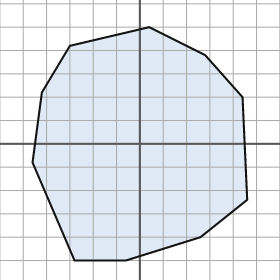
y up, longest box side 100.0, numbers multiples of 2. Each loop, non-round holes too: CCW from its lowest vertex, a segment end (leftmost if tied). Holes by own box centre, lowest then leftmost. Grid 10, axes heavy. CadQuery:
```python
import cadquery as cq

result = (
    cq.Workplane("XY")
    .moveTo(-28.0, -50.0)
    .lineTo(-6.0, -50.0)
    .lineTo(26.0, -40.0)
    .lineTo(46.0, -24.0)
    .lineTo(44.0, 20.0)
    .lineTo(28.0, 38.0)
    .lineTo(4.0, 50.0)
    .lineTo(-30.0, 42.0)
    .lineTo(-42.0, 22.0)
    .lineTo(-46.0, -8.0)
    .close()
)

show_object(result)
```